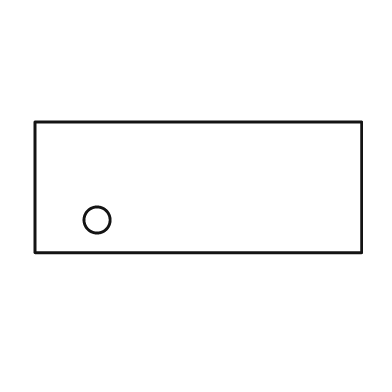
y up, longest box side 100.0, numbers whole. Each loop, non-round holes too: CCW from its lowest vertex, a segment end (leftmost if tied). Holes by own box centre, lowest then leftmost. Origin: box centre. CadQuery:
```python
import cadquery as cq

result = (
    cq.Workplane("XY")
    .moveTo(-50.0, -20.0)
    .lineTo(50.0, -20.0)
    .lineTo(50.0, 20.0)
    .lineTo(-50.0, 20.0)
    .close()
    .moveTo(-31.0, -10.0)
    .circle(4.0)
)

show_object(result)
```